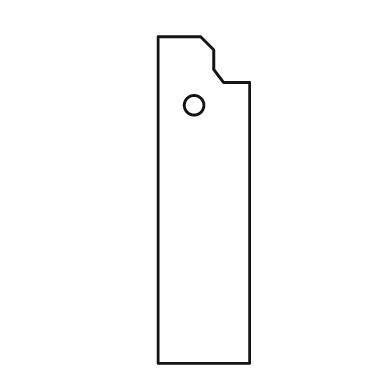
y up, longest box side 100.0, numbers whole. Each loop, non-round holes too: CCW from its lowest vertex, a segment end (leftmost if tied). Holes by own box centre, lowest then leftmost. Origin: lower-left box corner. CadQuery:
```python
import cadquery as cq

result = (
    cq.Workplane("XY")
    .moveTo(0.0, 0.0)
    .lineTo(28.0, 0.0)
    .lineTo(28.0, 86.0)
    .lineTo(20.0, 86.0)
    .lineTo(17.0, 90.0)
    .lineTo(17.0, 96.0)
    .lineTo(13.0, 100.0)
    .lineTo(0.0, 100.0)
    .close()
    .moveTo(11.0, 79.0)
    .circle(3.0)
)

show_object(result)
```